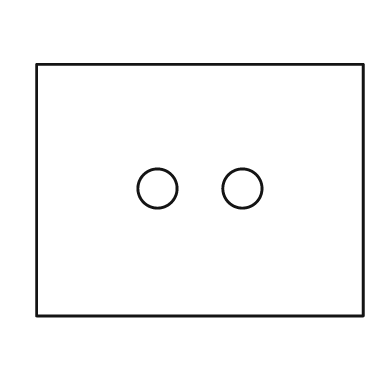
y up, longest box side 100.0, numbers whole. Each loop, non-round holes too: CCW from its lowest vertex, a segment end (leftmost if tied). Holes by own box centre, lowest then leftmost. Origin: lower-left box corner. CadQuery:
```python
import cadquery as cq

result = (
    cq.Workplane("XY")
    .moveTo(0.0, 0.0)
    .lineTo(100.0, 0.0)
    .lineTo(100.0, 77.0)
    .lineTo(0.0, 77.0)
    .close()
    .moveTo(37.0, 39.0)
    .circle(6.0)
    .moveTo(63.0, 39.0)
    .circle(6.0)
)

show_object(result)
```